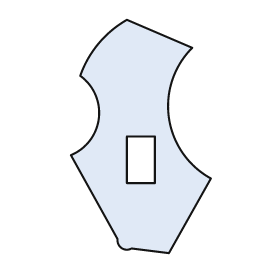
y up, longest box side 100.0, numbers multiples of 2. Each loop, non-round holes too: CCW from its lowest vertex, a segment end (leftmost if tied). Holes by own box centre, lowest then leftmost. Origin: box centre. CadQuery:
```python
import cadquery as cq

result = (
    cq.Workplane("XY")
    .moveTo(12.0, -50.0)
    .lineTo(30.0, -18.0)
    .threePointArc((12.0, 8.0), (22.0, 38.0))
    .lineTo(-6.0, 50.0)
    .threePointArc((-18.0, 40.0), (-26.0, 26.0))
    .threePointArc((-18.0, 8.0), (-30.0, -8.0))
    .lineTo(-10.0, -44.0)
    .threePointArc((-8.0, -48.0), (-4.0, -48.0))
    .close()
    .moveTo(-6.0, -20.0)
    .lineTo(6.0, -20.0)
    .lineTo(6.0, 0.0)
    .lineTo(-6.0, 0.0)
    .close()
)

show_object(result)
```